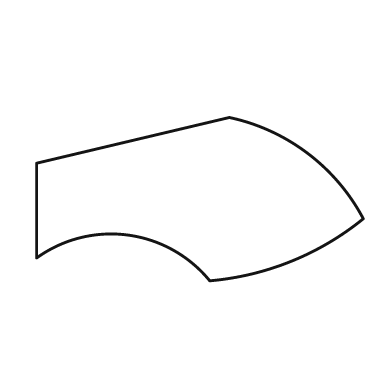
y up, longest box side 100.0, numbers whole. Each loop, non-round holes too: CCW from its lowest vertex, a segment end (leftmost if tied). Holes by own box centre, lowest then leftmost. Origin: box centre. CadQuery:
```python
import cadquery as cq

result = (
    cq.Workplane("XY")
    .moveTo(3.0, -25.0)
    .threePointArc((28.0, -19.0), (50.0, -6.0))
    .threePointArc((33.0, 14.0), (9.0, 25.0))
    .lineTo(-50.0, 11.0)
    .lineTo(-50.0, -18.0)
    .threePointArc((-22.0, -11.0), (3.0, -25.0))
    .close()
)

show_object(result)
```